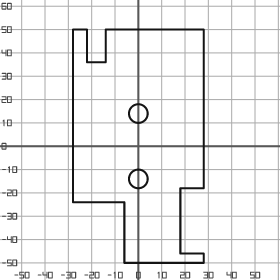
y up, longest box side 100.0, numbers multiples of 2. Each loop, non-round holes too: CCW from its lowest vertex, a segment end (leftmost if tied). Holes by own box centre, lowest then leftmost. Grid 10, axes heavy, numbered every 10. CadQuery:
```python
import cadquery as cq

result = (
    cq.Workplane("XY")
    .moveTo(-6.0, -50.0)
    .lineTo(28.0, -50.0)
    .lineTo(28.0, -46.0)
    .lineTo(18.0, -46.0)
    .lineTo(18.0, -18.0)
    .lineTo(28.0, -18.0)
    .lineTo(28.0, 50.0)
    .lineTo(-14.0, 50.0)
    .lineTo(-14.0, 36.0)
    .lineTo(-22.0, 36.0)
    .lineTo(-22.0, 50.0)
    .lineTo(-28.0, 50.0)
    .lineTo(-28.0, -24.0)
    .lineTo(-6.0, -24.0)
    .close()
    .moveTo(0.0, -14.0)
    .circle(4.0)
    .moveTo(0.0, 14.0)
    .circle(4.0)
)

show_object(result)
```